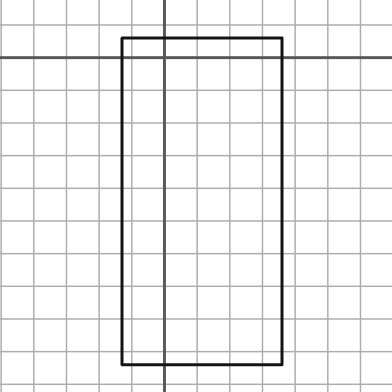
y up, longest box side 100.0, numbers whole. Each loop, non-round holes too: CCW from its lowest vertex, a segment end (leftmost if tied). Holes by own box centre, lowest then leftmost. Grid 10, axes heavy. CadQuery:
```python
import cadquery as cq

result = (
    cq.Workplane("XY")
    .moveTo(-13.0, -94.0)
    .lineTo(36.0, -94.0)
    .lineTo(36.0, 6.0)
    .lineTo(-13.0, 6.0)
    .close()
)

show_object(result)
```